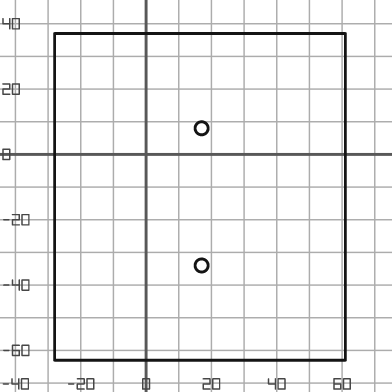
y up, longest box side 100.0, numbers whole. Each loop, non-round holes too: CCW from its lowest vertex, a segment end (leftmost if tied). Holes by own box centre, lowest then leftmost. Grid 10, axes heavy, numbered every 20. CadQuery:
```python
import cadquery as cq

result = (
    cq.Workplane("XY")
    .moveTo(-28.0, -63.0)
    .lineTo(61.0, -63.0)
    .lineTo(61.0, 37.0)
    .lineTo(-28.0, 37.0)
    .close()
    .moveTo(17.0, -34.0)
    .circle(2.0)
    .moveTo(17.0, 8.0)
    .circle(2.0)
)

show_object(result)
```